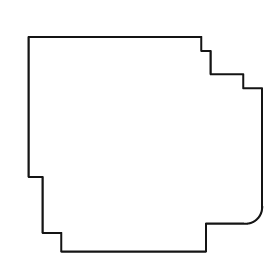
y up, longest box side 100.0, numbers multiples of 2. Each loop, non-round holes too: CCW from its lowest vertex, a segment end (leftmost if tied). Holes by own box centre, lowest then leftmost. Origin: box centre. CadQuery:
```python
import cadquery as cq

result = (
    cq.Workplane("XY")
    .moveTo(-36.0, -46.0)
    .lineTo(26.0, -46.0)
    .lineTo(26.0, -34.0)
    .lineTo(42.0, -34.0)
    .threePointArc((48.0, -32.0), (50.0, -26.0))
    .lineTo(50.0, 24.0)
    .lineTo(42.0, 24.0)
    .lineTo(42.0, 30.0)
    .lineTo(28.0, 30.0)
    .lineTo(28.0, 40.0)
    .lineTo(24.0, 40.0)
    .lineTo(24.0, 46.0)
    .lineTo(-50.0, 46.0)
    .lineTo(-50.0, -14.0)
    .lineTo(-44.0, -14.0)
    .lineTo(-44.0, -38.0)
    .lineTo(-36.0, -38.0)
    .close()
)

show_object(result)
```